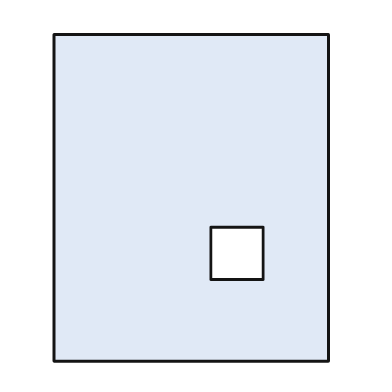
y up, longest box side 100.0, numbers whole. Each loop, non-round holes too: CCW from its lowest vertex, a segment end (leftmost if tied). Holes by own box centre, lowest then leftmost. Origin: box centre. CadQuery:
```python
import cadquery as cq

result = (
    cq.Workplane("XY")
    .moveTo(-42.0, -50.0)
    .lineTo(42.0, -50.0)
    .lineTo(42.0, 50.0)
    .lineTo(-42.0, 50.0)
    .close()
    .moveTo(6.0, -25.0)
    .lineTo(22.0, -25.0)
    .lineTo(22.0, -9.0)
    .lineTo(6.0, -9.0)
    .close()
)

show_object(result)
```